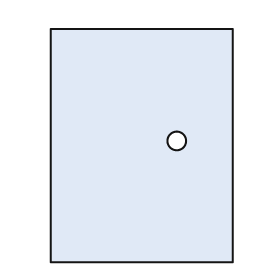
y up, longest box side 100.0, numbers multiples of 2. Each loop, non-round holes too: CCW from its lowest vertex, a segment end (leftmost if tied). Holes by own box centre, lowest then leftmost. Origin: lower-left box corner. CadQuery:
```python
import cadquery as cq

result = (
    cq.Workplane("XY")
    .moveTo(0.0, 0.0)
    .lineTo(78.0, 0.0)
    .lineTo(78.0, 100.0)
    .lineTo(0.0, 100.0)
    .close()
    .moveTo(54.0, 52.0)
    .circle(4.0)
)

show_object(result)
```